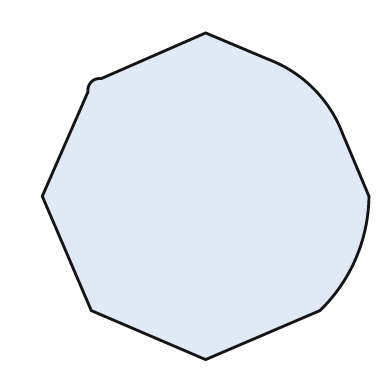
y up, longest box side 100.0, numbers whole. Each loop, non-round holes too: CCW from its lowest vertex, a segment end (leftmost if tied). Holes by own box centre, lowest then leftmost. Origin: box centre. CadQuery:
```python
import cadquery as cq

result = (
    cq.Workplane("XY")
    .moveTo(0.0, -50.0)
    .lineTo(35.0, -35.0)
    .threePointArc((46.0, -19.0), (50.0, 0.0))
    .lineTo(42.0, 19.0)
    .threePointArc((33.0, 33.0), (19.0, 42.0))
    .lineTo(0.0, 50.0)
    .lineTo(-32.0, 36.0)
    .threePointArc((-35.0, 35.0), (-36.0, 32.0))
    .lineTo(-50.0, 0.0)
    .lineTo(-35.0, -35.0)
    .close()
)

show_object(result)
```